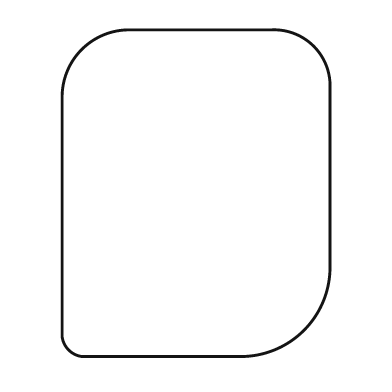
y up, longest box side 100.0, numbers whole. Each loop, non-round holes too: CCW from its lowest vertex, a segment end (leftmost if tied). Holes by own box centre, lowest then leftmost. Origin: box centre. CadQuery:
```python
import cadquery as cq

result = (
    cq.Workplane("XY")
    .moveTo(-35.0, -50.0)
    .lineTo(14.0, -50.0)
    .threePointArc((33.0, -42.0), (41.0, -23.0))
    .lineTo(41.0, 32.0)
    .threePointArc((36.0, 45.0), (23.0, 50.0))
    .lineTo(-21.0, 50.0)
    .threePointArc((-35.0, 44.0), (-41.0, 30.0))
    .lineTo(-41.0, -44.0)
    .threePointArc((-39.0, -48.0), (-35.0, -50.0))
    .close()
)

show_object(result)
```